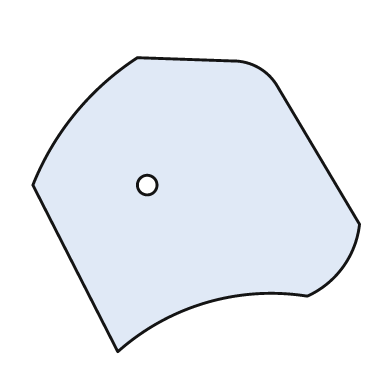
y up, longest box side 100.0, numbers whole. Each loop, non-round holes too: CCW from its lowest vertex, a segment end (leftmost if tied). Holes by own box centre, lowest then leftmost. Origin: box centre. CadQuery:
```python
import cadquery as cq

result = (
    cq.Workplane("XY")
    .moveTo(-24.0, -45.0)
    .threePointArc((3.0, -30.0), (34.0, -28.0))
    .threePointArc((45.0, -19.0), (50.0, -6.0))
    .lineTo(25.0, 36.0)
    .threePointArc((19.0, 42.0), (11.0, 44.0))
    .lineTo(-18.0, 45.0)
    .threePointArc((-37.0, 28.0), (-50.0, 6.0))
    .close()
    .moveTo(-15.0, 6.0)
    .circle(3.0)
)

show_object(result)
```